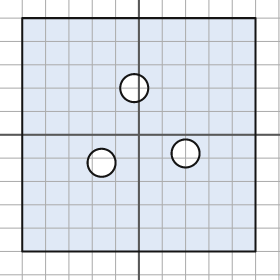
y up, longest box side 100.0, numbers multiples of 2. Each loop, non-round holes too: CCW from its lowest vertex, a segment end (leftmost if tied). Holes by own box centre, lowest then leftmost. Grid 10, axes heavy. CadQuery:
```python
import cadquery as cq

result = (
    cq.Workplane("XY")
    .moveTo(-50.0, -50.0)
    .lineTo(50.0, -50.0)
    .lineTo(50.0, 50.0)
    .lineTo(-50.0, 50.0)
    .close()
    .moveTo(-16.0, -12.0)
    .circle(6.0)
    .moveTo(20.0, -8.0)
    .circle(6.0)
    .moveTo(-2.0, 20.0)
    .circle(6.0)
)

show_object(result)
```